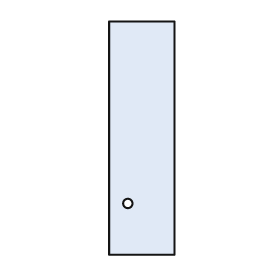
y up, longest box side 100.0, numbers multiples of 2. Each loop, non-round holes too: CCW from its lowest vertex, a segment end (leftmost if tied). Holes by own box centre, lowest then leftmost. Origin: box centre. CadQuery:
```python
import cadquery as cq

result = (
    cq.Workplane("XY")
    .moveTo(-14.0, -50.0)
    .lineTo(14.0, -50.0)
    .lineTo(14.0, 50.0)
    .lineTo(-14.0, 50.0)
    .close()
    .moveTo(-6.0, -28.0)
    .circle(2.0)
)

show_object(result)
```